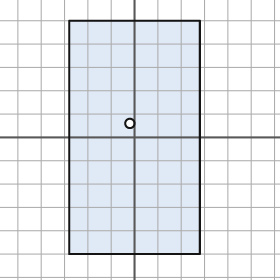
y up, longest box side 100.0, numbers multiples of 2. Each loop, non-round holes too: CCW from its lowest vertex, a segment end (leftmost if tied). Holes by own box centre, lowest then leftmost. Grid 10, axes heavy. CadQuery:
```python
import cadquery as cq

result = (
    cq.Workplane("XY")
    .moveTo(-28.0, -50.0)
    .lineTo(28.0, -50.0)
    .lineTo(28.0, 50.0)
    .lineTo(-28.0, 50.0)
    .close()
    .moveTo(-2.0, 6.0)
    .circle(2.0)
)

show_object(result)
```